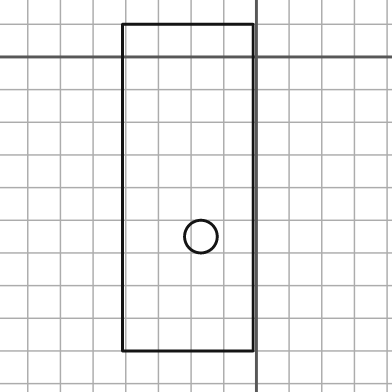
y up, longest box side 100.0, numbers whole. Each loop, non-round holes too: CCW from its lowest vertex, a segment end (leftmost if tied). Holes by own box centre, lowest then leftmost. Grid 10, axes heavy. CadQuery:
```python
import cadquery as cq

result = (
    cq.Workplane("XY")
    .moveTo(-41.0, -90.0)
    .lineTo(-1.0, -90.0)
    .lineTo(-1.0, 10.0)
    .lineTo(-41.0, 10.0)
    .close()
    .moveTo(-17.0, -55.0)
    .circle(5.0)
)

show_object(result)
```